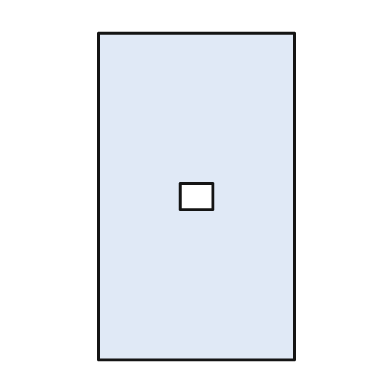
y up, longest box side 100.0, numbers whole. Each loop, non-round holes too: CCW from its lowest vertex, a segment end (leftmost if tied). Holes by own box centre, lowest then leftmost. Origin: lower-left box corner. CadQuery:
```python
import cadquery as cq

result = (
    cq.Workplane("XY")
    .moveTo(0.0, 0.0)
    .lineTo(60.0, 0.0)
    .lineTo(60.0, 100.0)
    .lineTo(0.0, 100.0)
    .close()
    .moveTo(25.0, 46.0)
    .lineTo(35.0, 46.0)
    .lineTo(35.0, 54.0)
    .lineTo(25.0, 54.0)
    .close()
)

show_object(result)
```